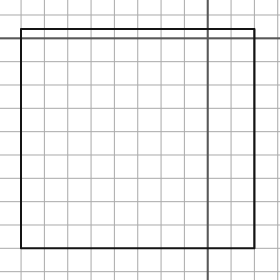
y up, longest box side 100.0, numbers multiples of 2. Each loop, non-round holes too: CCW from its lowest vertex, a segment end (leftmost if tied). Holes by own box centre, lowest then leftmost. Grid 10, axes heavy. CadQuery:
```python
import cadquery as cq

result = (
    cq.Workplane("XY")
    .moveTo(-80.0, -90.0)
    .lineTo(20.0, -90.0)
    .lineTo(20.0, 4.0)
    .lineTo(-80.0, 4.0)
    .close()
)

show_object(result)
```